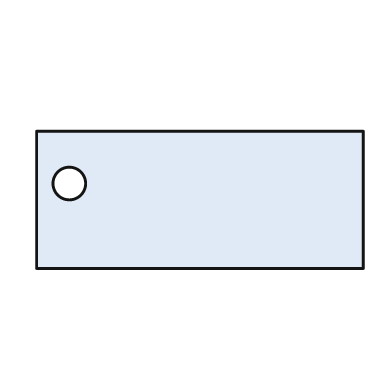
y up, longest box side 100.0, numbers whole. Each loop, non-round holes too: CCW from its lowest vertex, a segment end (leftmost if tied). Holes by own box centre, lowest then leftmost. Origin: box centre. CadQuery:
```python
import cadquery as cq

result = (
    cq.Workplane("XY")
    .moveTo(-50.0, -21.0)
    .lineTo(50.0, -21.0)
    .lineTo(50.0, 21.0)
    .lineTo(-50.0, 21.0)
    .close()
    .moveTo(-40.0, 5.0)
    .circle(5.0)
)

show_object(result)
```